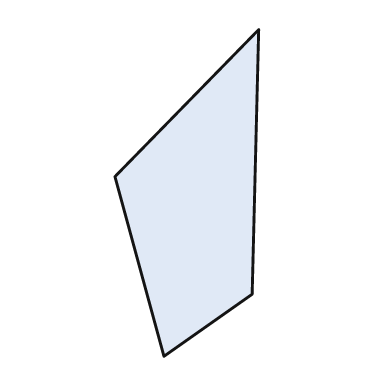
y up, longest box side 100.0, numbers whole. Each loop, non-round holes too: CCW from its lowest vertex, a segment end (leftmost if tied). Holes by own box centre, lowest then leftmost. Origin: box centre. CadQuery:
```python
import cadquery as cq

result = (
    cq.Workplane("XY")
    .moveTo(-7.0, -50.0)
    .lineTo(20.0, -31.0)
    .lineTo(22.0, 50.0)
    .lineTo(-22.0, 5.0)
    .close()
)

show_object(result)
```